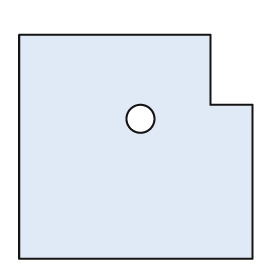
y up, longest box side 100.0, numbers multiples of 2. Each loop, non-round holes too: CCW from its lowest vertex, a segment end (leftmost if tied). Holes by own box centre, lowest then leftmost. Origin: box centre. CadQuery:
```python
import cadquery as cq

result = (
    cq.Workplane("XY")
    .moveTo(-50.0, -48.0)
    .lineTo(50.0, -48.0)
    .lineTo(50.0, 18.0)
    .lineTo(32.0, 18.0)
    .lineTo(32.0, 48.0)
    .lineTo(-50.0, 48.0)
    .close()
    .moveTo(2.0, 12.0)
    .circle(6.0)
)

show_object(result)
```